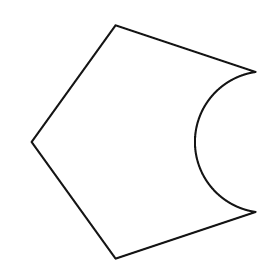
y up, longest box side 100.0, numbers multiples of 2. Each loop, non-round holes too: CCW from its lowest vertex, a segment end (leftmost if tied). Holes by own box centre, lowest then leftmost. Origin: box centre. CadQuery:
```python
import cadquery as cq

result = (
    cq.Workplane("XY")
    .moveTo(-12.0, -50.0)
    .lineTo(48.0, -30.0)
    .threePointArc((22.0, 0.0), (48.0, 30.0))
    .lineTo(-12.0, 50.0)
    .lineTo(-48.0, 0.0)
    .close()
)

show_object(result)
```